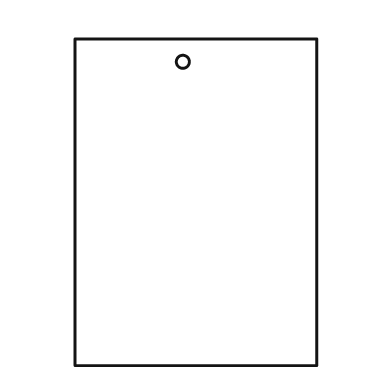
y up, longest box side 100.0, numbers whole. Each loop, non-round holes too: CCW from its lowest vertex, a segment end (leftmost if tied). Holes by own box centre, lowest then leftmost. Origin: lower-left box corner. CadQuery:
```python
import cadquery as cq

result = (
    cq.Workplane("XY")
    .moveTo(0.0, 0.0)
    .lineTo(74.0, 0.0)
    .lineTo(74.0, 100.0)
    .lineTo(0.0, 100.0)
    .close()
    .moveTo(33.0, 93.0)
    .circle(2.0)
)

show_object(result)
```